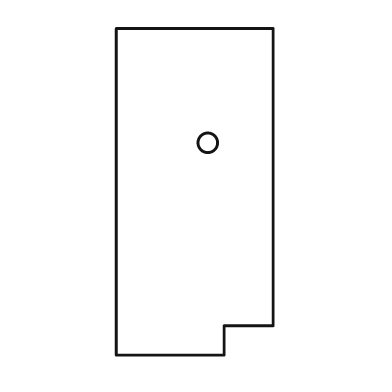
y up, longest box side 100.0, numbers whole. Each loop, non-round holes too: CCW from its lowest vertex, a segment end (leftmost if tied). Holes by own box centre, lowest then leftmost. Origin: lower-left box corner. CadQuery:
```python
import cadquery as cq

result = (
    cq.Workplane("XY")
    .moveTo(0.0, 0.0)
    .lineTo(33.0, 0.0)
    .lineTo(33.0, 9.0)
    .lineTo(48.0, 9.0)
    .lineTo(48.0, 100.0)
    .lineTo(0.0, 100.0)
    .close()
    .moveTo(28.0, 65.0)
    .circle(3.0)
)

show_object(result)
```